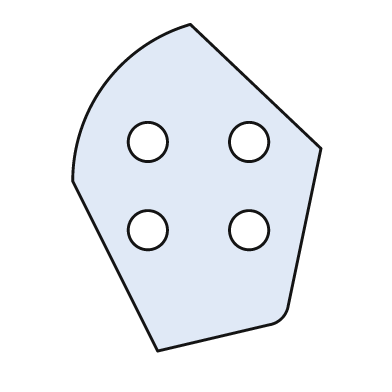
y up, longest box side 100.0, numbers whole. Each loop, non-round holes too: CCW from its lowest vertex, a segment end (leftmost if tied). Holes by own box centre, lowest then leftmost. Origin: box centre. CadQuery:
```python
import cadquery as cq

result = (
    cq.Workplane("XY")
    .moveTo(-12.0, -50.0)
    .lineTo(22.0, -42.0)
    .threePointArc((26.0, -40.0), (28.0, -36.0))
    .lineTo(38.0, 12.0)
    .lineTo(-2.0, 50.0)
    .threePointArc((-28.0, 32.0), (-38.0, 2.0))
    .close()
    .moveTo(-15.0, -13.0)
    .circle(6.0)
    .moveTo(16.0, -13.0)
    .circle(6.0)
    .moveTo(-15.0, 14.0)
    .circle(6.0)
    .moveTo(16.0, 14.0)
    .circle(6.0)
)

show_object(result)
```